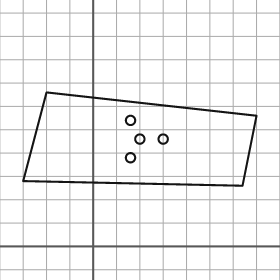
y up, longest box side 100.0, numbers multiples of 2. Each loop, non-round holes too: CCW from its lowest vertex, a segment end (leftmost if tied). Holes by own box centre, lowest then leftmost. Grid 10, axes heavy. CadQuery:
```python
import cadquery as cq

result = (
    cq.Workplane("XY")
    .moveTo(64.0, 26.0)
    .lineTo(70.0, 56.0)
    .lineTo(-20.0, 66.0)
    .lineTo(-30.0, 28.0)
    .close()
    .moveTo(16.0, 38.0)
    .circle(2.0)
    .moveTo(20.0, 46.0)
    .circle(2.0)
    .moveTo(30.0, 46.0)
    .circle(2.0)
    .moveTo(16.0, 54.0)
    .circle(2.0)
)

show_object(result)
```